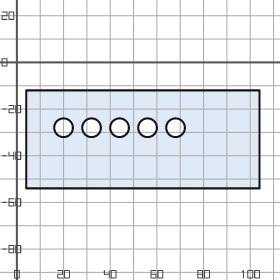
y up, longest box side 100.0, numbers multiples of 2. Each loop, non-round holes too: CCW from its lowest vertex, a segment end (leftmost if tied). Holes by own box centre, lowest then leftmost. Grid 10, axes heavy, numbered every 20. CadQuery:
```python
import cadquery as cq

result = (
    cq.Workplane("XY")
    .moveTo(4.0, -54.0)
    .lineTo(104.0, -54.0)
    .lineTo(104.0, -12.0)
    .lineTo(4.0, -12.0)
    .close()
    .moveTo(20.0, -28.0)
    .circle(4.0)
    .moveTo(32.0, -28.0)
    .circle(4.0)
    .moveTo(44.0, -28.0)
    .circle(4.0)
    .moveTo(56.0, -28.0)
    .circle(4.0)
    .moveTo(68.0, -28.0)
    .circle(4.0)
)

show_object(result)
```